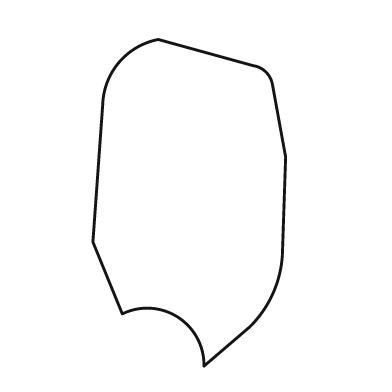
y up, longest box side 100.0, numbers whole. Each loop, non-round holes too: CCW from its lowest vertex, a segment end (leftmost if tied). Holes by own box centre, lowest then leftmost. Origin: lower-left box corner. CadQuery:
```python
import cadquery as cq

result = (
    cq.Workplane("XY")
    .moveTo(34.0, 0.0)
    .lineTo(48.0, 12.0)
    .threePointArc((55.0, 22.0), (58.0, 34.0))
    .lineTo(59.0, 64.0)
    .lineTo(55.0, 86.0)
    .threePointArc((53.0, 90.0), (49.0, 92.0))
    .lineTo(20.0, 100.0)
    .threePointArc((8.0, 93.0), (3.0, 80.0))
    .lineTo(0.0, 38.0)
    .lineTo(9.0, 16.0)
    .threePointArc((26.0, 15.0), (34.0, 0.0))
    .close()
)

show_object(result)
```